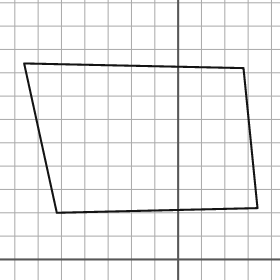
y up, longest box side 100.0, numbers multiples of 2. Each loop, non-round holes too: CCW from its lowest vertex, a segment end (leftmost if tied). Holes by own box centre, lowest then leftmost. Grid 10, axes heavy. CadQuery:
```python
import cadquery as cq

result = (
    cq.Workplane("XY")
    .moveTo(-52.0, 20.0)
    .lineTo(34.0, 22.0)
    .lineTo(28.0, 82.0)
    .lineTo(-66.0, 84.0)
    .close()
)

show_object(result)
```